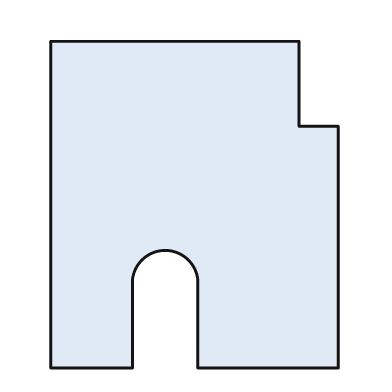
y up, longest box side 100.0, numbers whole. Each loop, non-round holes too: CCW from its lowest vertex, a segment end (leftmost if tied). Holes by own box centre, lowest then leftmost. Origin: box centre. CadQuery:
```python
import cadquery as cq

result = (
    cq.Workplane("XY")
    .moveTo(-44.0, -50.0)
    .lineTo(-19.0, -50.0)
    .lineTo(-19.0, -23.0)
    .threePointArc((-9.0, -14.0), (1.0, -23.0))
    .lineTo(1.0, -50.0)
    .lineTo(44.0, -50.0)
    .lineTo(44.0, 24.0)
    .lineTo(32.0, 24.0)
    .lineTo(32.0, 50.0)
    .lineTo(-44.0, 50.0)
    .close()
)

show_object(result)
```